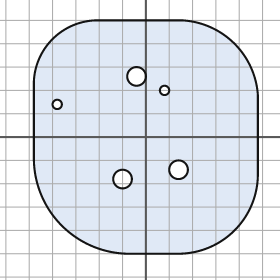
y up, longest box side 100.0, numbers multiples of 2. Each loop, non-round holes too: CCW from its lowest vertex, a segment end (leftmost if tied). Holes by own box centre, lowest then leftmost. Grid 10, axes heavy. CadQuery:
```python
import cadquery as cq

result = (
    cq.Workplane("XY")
    .moveTo(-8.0, -50.0)
    .lineTo(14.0, -50.0)
    .threePointArc((38.0, -40.0), (48.0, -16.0))
    .lineTo(48.0, 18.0)
    .threePointArc((38.0, 40.0), (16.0, 50.0))
    .lineTo(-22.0, 50.0)
    .threePointArc((-40.0, 42.0), (-48.0, 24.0))
    .lineTo(-48.0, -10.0)
    .threePointArc((-36.0, -38.0), (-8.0, -50.0))
    .close()
    .moveTo(-10.0, -18.0)
    .circle(4.0)
    .moveTo(14.0, -14.0)
    .circle(4.0)
    .moveTo(-38.0, 14.0)
    .circle(2.0)
    .moveTo(8.0, 20.0)
    .circle(2.0)
    .moveTo(-4.0, 26.0)
    .circle(4.0)
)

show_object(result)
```